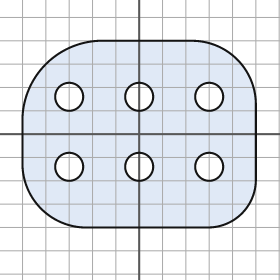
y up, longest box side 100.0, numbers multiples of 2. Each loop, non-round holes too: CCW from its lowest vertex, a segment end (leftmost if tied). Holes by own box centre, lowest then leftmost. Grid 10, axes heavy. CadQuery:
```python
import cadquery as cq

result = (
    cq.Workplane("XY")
    .moveTo(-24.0, -40.0)
    .lineTo(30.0, -40.0)
    .threePointArc((44.0, -34.0), (50.0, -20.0))
    .lineTo(50.0, 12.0)
    .threePointArc((42.0, 32.0), (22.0, 40.0))
    .lineTo(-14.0, 40.0)
    .threePointArc((-40.0, 30.0), (-50.0, 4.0))
    .lineTo(-50.0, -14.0)
    .threePointArc((-42.0, -32.0), (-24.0, -40.0))
    .close()
    .moveTo(-30.0, -14.0)
    .circle(6.0)
    .moveTo(0.0, -14.0)
    .circle(6.0)
    .moveTo(30.0, -14.0)
    .circle(6.0)
    .moveTo(-30.0, 16.0)
    .circle(6.0)
    .moveTo(0.0, 16.0)
    .circle(6.0)
    .moveTo(30.0, 16.0)
    .circle(6.0)
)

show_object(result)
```